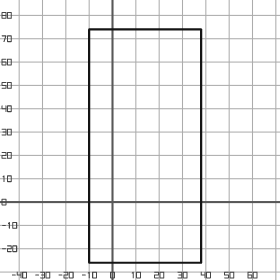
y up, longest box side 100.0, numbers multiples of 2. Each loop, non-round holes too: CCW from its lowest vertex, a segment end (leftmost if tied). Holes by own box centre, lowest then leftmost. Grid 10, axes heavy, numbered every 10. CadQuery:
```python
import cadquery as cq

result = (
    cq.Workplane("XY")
    .moveTo(-10.0, -26.0)
    .lineTo(38.0, -26.0)
    .lineTo(38.0, 74.0)
    .lineTo(-10.0, 74.0)
    .close()
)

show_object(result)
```